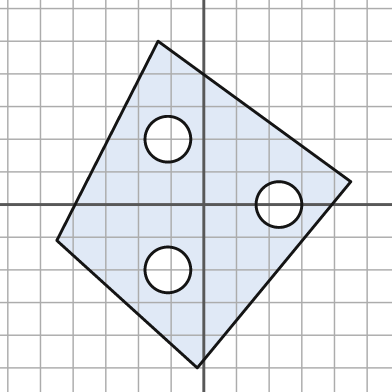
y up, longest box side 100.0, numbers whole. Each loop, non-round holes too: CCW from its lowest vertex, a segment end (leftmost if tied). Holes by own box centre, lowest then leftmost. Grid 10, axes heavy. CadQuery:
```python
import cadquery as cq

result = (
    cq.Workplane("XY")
    .moveTo(-2.0, -50.0)
    .lineTo(45.0, 7.0)
    .lineTo(-14.0, 50.0)
    .lineTo(-45.0, -11.0)
    .close()
    .moveTo(-11.0, -20.0)
    .circle(7.0)
    .moveTo(23.0, 0.0)
    .circle(7.0)
    .moveTo(-11.0, 20.0)
    .circle(7.0)
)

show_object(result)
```